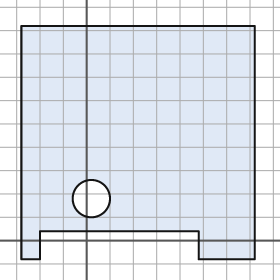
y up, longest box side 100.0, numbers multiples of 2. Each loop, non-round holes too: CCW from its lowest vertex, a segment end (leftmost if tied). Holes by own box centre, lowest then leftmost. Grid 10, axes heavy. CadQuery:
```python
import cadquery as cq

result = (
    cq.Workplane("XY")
    .moveTo(-28.0, -8.0)
    .lineTo(-20.0, -8.0)
    .lineTo(-20.0, 4.0)
    .lineTo(48.0, 4.0)
    .lineTo(48.0, -8.0)
    .lineTo(72.0, -8.0)
    .lineTo(72.0, 92.0)
    .lineTo(-28.0, 92.0)
    .close()
    .moveTo(2.0, 18.0)
    .circle(8.0)
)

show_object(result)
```